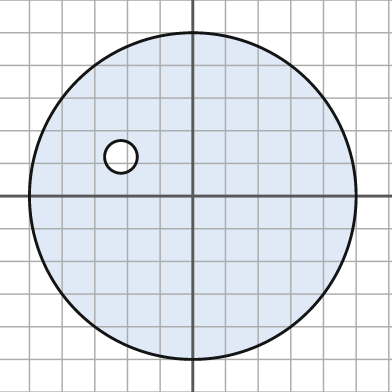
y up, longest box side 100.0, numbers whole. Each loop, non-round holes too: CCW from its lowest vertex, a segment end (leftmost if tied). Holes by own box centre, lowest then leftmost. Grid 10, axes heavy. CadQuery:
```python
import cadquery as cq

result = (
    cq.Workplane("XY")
    .moveTo(0.0, 0.0)
    .circle(50.0)
    .moveTo(-22.0, 12.0)
    .circle(5.0)
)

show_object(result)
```